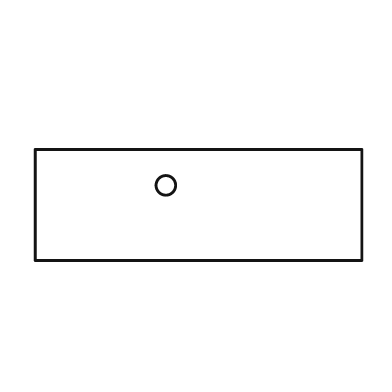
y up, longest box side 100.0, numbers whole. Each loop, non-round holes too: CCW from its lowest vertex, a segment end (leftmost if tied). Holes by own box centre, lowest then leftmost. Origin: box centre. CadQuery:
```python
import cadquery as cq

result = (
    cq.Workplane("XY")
    .moveTo(-50.0, -17.0)
    .lineTo(50.0, -17.0)
    .lineTo(50.0, 17.0)
    .lineTo(-50.0, 17.0)
    .close()
    .moveTo(-10.0, 6.0)
    .circle(3.0)
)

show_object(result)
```